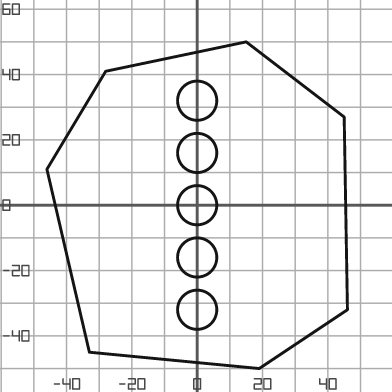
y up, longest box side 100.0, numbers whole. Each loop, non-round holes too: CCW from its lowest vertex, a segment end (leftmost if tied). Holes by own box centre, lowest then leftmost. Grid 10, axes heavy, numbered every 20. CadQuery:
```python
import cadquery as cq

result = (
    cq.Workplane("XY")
    .moveTo(19.0, -50.0)
    .lineTo(46.0, -32.0)
    .lineTo(45.0, 27.0)
    .lineTo(15.0, 50.0)
    .lineTo(-28.0, 41.0)
    .lineTo(-46.0, 11.0)
    .lineTo(-33.0, -45.0)
    .close()
    .moveTo(0.0, -32.0)
    .circle(6.0)
    .moveTo(0.0, -16.0)
    .circle(6.0)
    .moveTo(0.0, 0.0)
    .circle(6.0)
    .moveTo(0.0, 16.0)
    .circle(6.0)
    .moveTo(0.0, 32.0)
    .circle(6.0)
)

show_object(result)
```